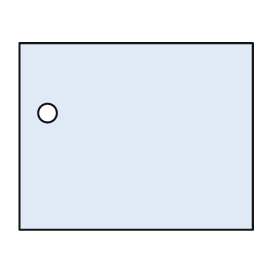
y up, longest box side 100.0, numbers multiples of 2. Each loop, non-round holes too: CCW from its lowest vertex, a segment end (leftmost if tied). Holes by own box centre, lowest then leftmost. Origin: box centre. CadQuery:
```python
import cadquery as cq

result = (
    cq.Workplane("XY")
    .moveTo(-50.0, -40.0)
    .lineTo(50.0, -40.0)
    .lineTo(50.0, 40.0)
    .lineTo(-50.0, 40.0)
    .close()
    .moveTo(-38.0, 10.0)
    .circle(4.0)
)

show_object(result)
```